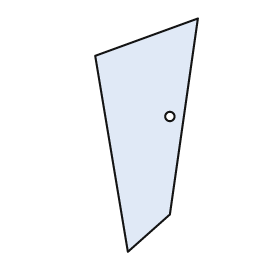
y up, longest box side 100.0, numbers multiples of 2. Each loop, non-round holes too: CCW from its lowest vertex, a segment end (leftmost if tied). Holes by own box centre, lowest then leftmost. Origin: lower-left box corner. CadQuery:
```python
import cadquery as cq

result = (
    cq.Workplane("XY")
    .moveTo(14.0, 0.0)
    .lineTo(32.0, 16.0)
    .lineTo(44.0, 100.0)
    .lineTo(0.0, 84.0)
    .close()
    .moveTo(32.0, 58.0)
    .circle(2.0)
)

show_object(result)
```